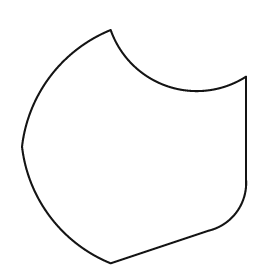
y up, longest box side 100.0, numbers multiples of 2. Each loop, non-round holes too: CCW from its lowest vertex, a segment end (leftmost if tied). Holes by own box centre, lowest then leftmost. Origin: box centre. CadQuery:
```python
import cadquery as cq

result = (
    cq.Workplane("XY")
    .moveTo(-10.0, -50.0)
    .lineTo(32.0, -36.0)
    .threePointArc((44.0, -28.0), (48.0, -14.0))
    .lineTo(48.0, 30.0)
    .threePointArc((14.0, 26.0), (-10.0, 50.0))
    .threePointArc((-36.0, 30.0), (-48.0, 0.0))
    .threePointArc((-36.0, -30.0), (-10.0, -50.0))
    .close()
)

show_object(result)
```